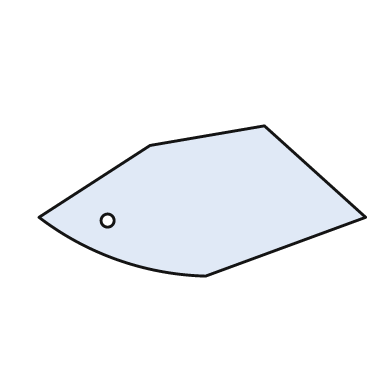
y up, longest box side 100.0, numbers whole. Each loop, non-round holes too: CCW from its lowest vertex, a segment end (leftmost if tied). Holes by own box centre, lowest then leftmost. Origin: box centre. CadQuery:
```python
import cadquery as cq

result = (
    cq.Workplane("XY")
    .moveTo(1.0, -23.0)
    .lineTo(50.0, -5.0)
    .lineTo(19.0, 23.0)
    .lineTo(-16.0, 17.0)
    .lineTo(-50.0, -5.0)
    .threePointArc((-26.0, -18.0), (1.0, -23.0))
    .close()
    .moveTo(-29.0, -6.0)
    .circle(2.0)
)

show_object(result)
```